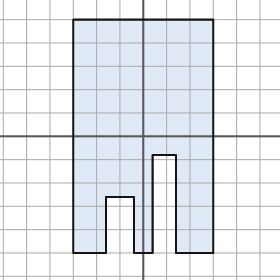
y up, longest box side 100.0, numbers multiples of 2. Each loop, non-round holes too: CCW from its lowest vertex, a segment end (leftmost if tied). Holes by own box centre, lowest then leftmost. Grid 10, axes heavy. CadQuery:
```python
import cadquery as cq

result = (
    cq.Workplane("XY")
    .moveTo(-30.0, -50.0)
    .lineTo(-16.0, -50.0)
    .lineTo(-16.0, -26.0)
    .lineTo(-4.0, -26.0)
    .lineTo(-4.0, -50.0)
    .lineTo(4.0, -50.0)
    .lineTo(4.0, -8.0)
    .lineTo(14.0, -8.0)
    .lineTo(14.0, -50.0)
    .lineTo(30.0, -50.0)
    .lineTo(30.0, 50.0)
    .lineTo(-30.0, 50.0)
    .close()
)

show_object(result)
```